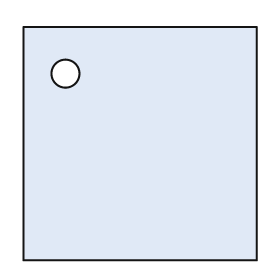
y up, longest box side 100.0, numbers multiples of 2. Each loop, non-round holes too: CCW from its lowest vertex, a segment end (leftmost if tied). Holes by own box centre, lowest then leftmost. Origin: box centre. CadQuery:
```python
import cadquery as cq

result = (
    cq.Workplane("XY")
    .moveTo(-50.0, -50.0)
    .lineTo(50.0, -50.0)
    .lineTo(50.0, 50.0)
    .lineTo(-50.0, 50.0)
    .close()
    .moveTo(-32.0, 30.0)
    .circle(6.0)
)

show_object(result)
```